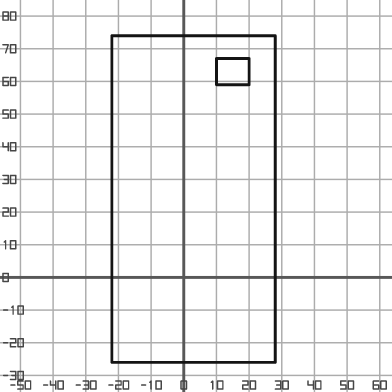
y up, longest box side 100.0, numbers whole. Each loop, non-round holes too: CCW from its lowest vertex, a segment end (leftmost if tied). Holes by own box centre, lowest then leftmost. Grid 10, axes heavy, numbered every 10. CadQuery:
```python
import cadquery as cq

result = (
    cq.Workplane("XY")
    .moveTo(-22.0, -26.0)
    .lineTo(28.0, -26.0)
    .lineTo(28.0, 74.0)
    .lineTo(-22.0, 74.0)
    .close()
    .moveTo(10.0, 59.0)
    .lineTo(20.0, 59.0)
    .lineTo(20.0, 67.0)
    .lineTo(10.0, 67.0)
    .close()
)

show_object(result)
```